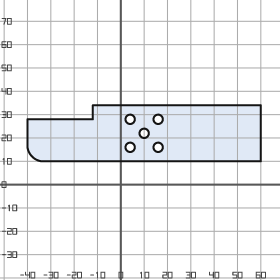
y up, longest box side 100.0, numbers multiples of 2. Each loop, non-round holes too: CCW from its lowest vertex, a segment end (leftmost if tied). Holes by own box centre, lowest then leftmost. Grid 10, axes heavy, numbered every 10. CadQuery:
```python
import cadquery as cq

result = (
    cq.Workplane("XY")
    .moveTo(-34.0, 10.0)
    .lineTo(60.0, 10.0)
    .lineTo(60.0, 34.0)
    .lineTo(-12.0, 34.0)
    .lineTo(-12.0, 28.0)
    .lineTo(-40.0, 28.0)
    .lineTo(-40.0, 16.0)
    .threePointArc((-38.0, 12.0), (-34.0, 10.0))
    .close()
    .moveTo(4.0, 16.0)
    .circle(2.0)
    .moveTo(16.0, 16.0)
    .circle(2.0)
    .moveTo(10.0, 22.0)
    .circle(2.0)
    .moveTo(4.0, 28.0)
    .circle(2.0)
    .moveTo(16.0, 28.0)
    .circle(2.0)
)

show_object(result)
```